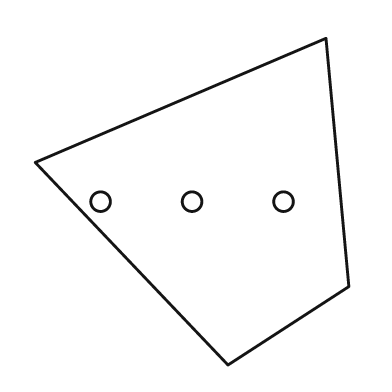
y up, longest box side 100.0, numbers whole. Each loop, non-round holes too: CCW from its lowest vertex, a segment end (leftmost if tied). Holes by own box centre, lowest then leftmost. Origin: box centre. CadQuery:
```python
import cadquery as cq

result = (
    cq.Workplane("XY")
    .moveTo(11.0, -50.0)
    .lineTo(48.0, -26.0)
    .lineTo(41.0, 50.0)
    .lineTo(-48.0, 12.0)
    .close()
    .moveTo(-28.0, 0.0)
    .circle(3.0)
    .moveTo(0.0, 0.0)
    .circle(3.0)
    .moveTo(28.0, 0.0)
    .circle(3.0)
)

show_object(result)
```